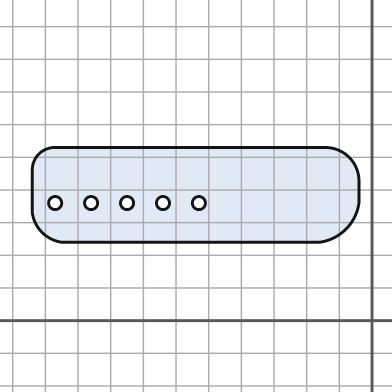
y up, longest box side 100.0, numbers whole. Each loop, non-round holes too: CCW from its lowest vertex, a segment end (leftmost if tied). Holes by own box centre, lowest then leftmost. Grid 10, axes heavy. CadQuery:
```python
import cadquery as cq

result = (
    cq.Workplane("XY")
    .moveTo(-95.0, 24.0)
    .lineTo(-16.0, 24.0)
    .threePointArc((-8.0, 28.0), (-4.0, 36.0))
    .lineTo(-4.0, 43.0)
    .threePointArc((-7.0, 50.0), (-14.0, 53.0))
    .lineTo(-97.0, 53.0)
    .threePointArc((-102.0, 51.0), (-104.0, 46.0))
    .lineTo(-104.0, 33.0)
    .threePointArc((-101.0, 27.0), (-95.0, 24.0))
    .close()
    .moveTo(-97.0, 36.0)
    .circle(2.0)
    .moveTo(-86.0, 36.0)
    .circle(2.0)
    .moveTo(-75.0, 36.0)
    .circle(2.0)
    .moveTo(-64.0, 36.0)
    .circle(2.0)
    .moveTo(-53.0, 36.0)
    .circle(2.0)
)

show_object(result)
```